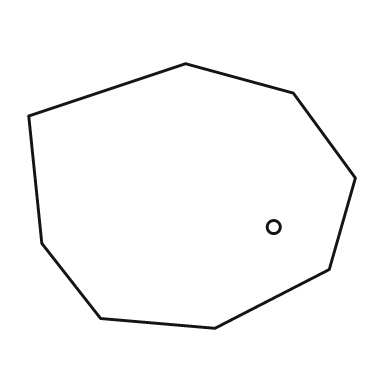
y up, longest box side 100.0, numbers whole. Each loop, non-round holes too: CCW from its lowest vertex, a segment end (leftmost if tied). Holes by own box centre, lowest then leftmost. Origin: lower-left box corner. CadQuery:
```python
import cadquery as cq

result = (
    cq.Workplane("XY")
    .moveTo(57.0, 0.0)
    .lineTo(92.0, 18.0)
    .lineTo(100.0, 46.0)
    .lineTo(81.0, 72.0)
    .lineTo(48.0, 81.0)
    .lineTo(0.0, 65.0)
    .lineTo(4.0, 26.0)
    .lineTo(22.0, 3.0)
    .close()
    .moveTo(75.0, 31.0)
    .circle(2.0)
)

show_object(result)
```